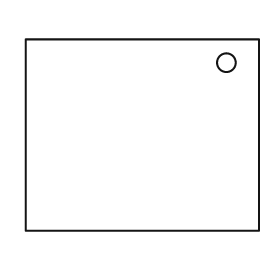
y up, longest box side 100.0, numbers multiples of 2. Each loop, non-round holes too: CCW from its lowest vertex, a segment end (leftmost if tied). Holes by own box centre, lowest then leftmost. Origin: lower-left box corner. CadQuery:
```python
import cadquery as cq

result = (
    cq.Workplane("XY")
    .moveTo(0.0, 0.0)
    .lineTo(100.0, 0.0)
    .lineTo(100.0, 82.0)
    .lineTo(0.0, 82.0)
    .close()
    .moveTo(86.0, 72.0)
    .circle(4.0)
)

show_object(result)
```